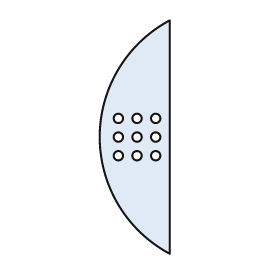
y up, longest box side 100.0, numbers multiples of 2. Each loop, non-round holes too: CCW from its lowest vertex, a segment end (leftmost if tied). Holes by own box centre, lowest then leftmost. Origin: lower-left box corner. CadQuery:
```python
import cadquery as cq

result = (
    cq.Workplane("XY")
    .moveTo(30.0, 0.0)
    .lineTo(30.0, 100.0)
    .threePointArc((0.0, 50.0), (30.0, 0.0))
    .close()
    .moveTo(8.0, 42.0)
    .circle(2.0)
    .moveTo(16.0, 42.0)
    .circle(2.0)
    .moveTo(24.0, 42.0)
    .circle(2.0)
    .moveTo(8.0, 50.0)
    .circle(2.0)
    .moveTo(16.0, 50.0)
    .circle(2.0)
    .moveTo(24.0, 50.0)
    .circle(2.0)
    .moveTo(8.0, 58.0)
    .circle(2.0)
    .moveTo(16.0, 58.0)
    .circle(2.0)
    .moveTo(24.0, 58.0)
    .circle(2.0)
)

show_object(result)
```